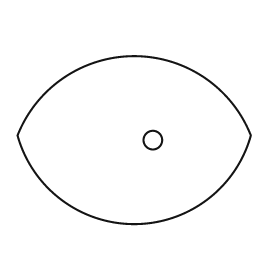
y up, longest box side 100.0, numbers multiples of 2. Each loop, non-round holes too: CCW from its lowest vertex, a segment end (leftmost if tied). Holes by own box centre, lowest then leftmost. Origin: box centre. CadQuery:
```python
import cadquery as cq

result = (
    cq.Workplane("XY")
    .moveTo(-50.0, 2.0)
    .threePointArc((0.0, -36.0), (50.0, 2.0))
    .threePointArc((0.0, 36.0), (-50.0, 2.0))
    .close()
    .moveTo(8.0, 0.0)
    .circle(4.0)
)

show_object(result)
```